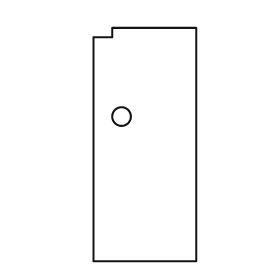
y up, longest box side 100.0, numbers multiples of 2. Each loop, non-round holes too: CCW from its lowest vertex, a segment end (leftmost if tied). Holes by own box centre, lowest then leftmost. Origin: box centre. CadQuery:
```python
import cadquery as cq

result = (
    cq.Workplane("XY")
    .moveTo(-22.0, -50.0)
    .lineTo(22.0, -50.0)
    .lineTo(22.0, 50.0)
    .lineTo(-14.0, 50.0)
    .lineTo(-14.0, 46.0)
    .lineTo(-22.0, 46.0)
    .close()
    .moveTo(-10.0, 12.0)
    .circle(4.0)
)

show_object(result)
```